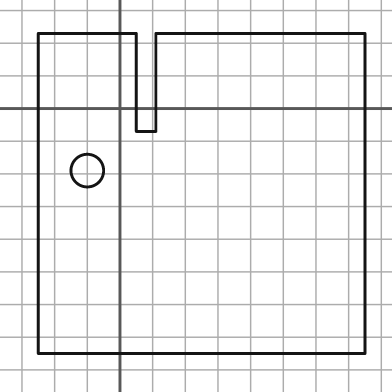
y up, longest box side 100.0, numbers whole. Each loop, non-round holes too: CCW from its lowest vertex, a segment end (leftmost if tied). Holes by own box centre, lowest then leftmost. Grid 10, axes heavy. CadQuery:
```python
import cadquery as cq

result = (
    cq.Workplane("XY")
    .moveTo(-25.0, -75.0)
    .lineTo(75.0, -75.0)
    .lineTo(75.0, 23.0)
    .lineTo(11.0, 23.0)
    .lineTo(11.0, -7.0)
    .lineTo(5.0, -7.0)
    .lineTo(5.0, 23.0)
    .lineTo(-25.0, 23.0)
    .close()
    .moveTo(-10.0, -19.0)
    .circle(5.0)
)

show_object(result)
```